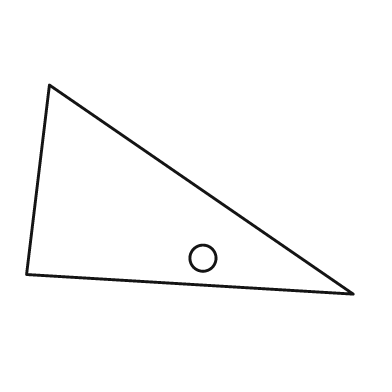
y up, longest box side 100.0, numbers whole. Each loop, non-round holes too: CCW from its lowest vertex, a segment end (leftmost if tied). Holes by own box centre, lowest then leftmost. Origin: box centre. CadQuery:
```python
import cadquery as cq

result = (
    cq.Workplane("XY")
    .moveTo(50.0, -32.0)
    .lineTo(-43.0, 32.0)
    .lineTo(-50.0, -26.0)
    .close()
    .moveTo(4.0, -21.0)
    .circle(4.0)
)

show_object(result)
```